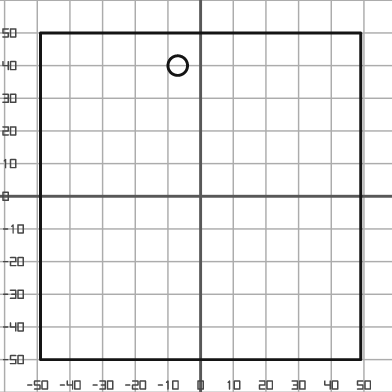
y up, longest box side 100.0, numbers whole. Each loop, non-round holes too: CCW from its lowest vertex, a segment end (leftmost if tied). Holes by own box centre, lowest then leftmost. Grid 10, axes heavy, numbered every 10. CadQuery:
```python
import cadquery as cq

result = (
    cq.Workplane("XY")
    .moveTo(-49.0, -50.0)
    .lineTo(49.0, -50.0)
    .lineTo(49.0, 50.0)
    .lineTo(-49.0, 50.0)
    .close()
    .moveTo(-7.0, 40.0)
    .circle(3.0)
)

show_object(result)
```